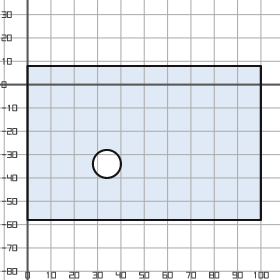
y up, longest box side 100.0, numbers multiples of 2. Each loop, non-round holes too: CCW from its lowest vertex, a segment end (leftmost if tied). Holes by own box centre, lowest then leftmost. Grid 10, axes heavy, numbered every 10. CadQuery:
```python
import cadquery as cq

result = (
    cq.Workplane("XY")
    .moveTo(0.0, -58.0)
    .lineTo(100.0, -58.0)
    .lineTo(100.0, 8.0)
    .lineTo(0.0, 8.0)
    .close()
    .moveTo(34.0, -34.0)
    .circle(6.0)
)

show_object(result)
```